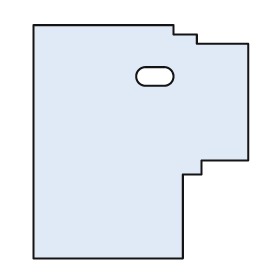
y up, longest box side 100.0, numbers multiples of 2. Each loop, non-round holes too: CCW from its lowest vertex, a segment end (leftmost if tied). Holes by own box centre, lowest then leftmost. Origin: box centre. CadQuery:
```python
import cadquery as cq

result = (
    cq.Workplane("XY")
    .moveTo(-46.0, -50.0)
    .lineTo(18.0, -50.0)
    .lineTo(18.0, -14.0)
    .lineTo(26.0, -14.0)
    .lineTo(26.0, -8.0)
    .lineTo(46.0, -8.0)
    .lineTo(46.0, 42.0)
    .lineTo(24.0, 42.0)
    .lineTo(24.0, 46.0)
    .lineTo(14.0, 46.0)
    .lineTo(14.0, 50.0)
    .lineTo(-46.0, 50.0)
    .close()
    .moveTo(2.0, 24.0)
    .lineTo(10.0, 24.0)
    .threePointArc((14.0, 28.0), (10.0, 32.0))
    .lineTo(2.0, 32.0)
    .threePointArc((-2.0, 28.0), (2.0, 24.0))
    .close()
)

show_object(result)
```